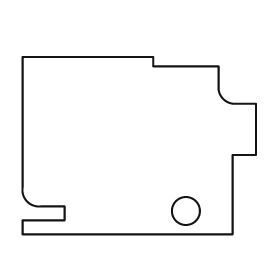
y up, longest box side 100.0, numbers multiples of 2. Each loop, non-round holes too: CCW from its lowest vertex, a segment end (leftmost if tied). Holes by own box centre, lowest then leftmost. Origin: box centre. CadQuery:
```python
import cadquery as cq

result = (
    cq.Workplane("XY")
    .moveTo(-50.0, -38.0)
    .lineTo(40.0, -38.0)
    .lineTo(40.0, -4.0)
    .lineTo(50.0, -4.0)
    .lineTo(50.0, 18.0)
    .lineTo(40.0, 18.0)
    .threePointArc((36.0, 20.0), (34.0, 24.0))
    .lineTo(34.0, 34.0)
    .lineTo(6.0, 34.0)
    .lineTo(6.0, 38.0)
    .lineTo(-50.0, 38.0)
    .lineTo(-50.0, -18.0)
    .threePointArc((-48.0, -24.0), (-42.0, -26.0))
    .lineTo(-32.0, -26.0)
    .lineTo(-32.0, -32.0)
    .lineTo(-50.0, -32.0)
    .close()
    .moveTo(20.0, -28.0)
    .circle(6.0)
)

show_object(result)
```